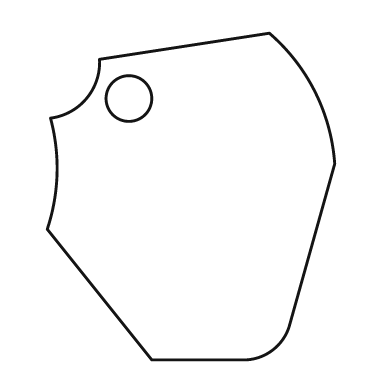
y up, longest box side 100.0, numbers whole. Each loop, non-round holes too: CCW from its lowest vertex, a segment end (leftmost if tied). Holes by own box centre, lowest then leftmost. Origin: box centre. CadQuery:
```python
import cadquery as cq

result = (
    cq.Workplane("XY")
    .moveTo(-12.0, -50.0)
    .lineTo(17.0, -50.0)
    .threePointArc((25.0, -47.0), (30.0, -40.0))
    .lineTo(44.0, 10.0)
    .threePointArc((38.0, 32.0), (24.0, 50.0))
    .lineTo(-28.0, 42.0)
    .threePointArc((-32.0, 30.0), (-43.0, 24.0))
    .threePointArc((-41.0, 7.0), (-44.0, -10.0))
    .close()
    .moveTo(-19.0, 30.0)
    .circle(7.0)
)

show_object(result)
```